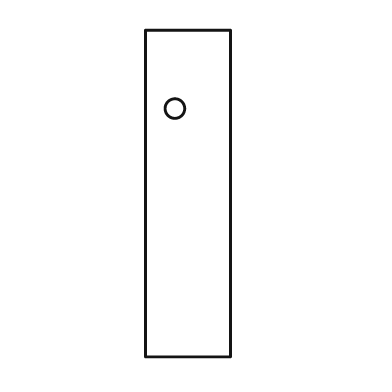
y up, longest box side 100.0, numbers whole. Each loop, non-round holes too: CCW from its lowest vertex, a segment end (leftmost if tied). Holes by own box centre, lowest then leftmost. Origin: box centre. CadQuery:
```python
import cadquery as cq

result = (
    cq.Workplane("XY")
    .moveTo(-13.0, -50.0)
    .lineTo(13.0, -50.0)
    .lineTo(13.0, 50.0)
    .lineTo(-13.0, 50.0)
    .close()
    .moveTo(-4.0, 26.0)
    .circle(3.0)
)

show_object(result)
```